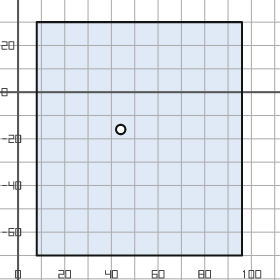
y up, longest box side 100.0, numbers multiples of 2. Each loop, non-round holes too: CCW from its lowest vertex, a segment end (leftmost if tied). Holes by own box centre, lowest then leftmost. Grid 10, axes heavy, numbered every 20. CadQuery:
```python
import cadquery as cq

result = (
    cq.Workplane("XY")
    .moveTo(8.0, -70.0)
    .lineTo(96.0, -70.0)
    .lineTo(96.0, 30.0)
    .lineTo(8.0, 30.0)
    .close()
    .moveTo(44.0, -16.0)
    .circle(2.0)
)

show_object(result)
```